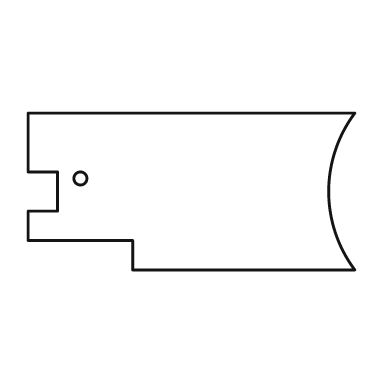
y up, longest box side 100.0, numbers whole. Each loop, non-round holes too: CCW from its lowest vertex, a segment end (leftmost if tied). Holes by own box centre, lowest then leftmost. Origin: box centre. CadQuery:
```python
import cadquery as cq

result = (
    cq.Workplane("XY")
    .moveTo(-18.0, -24.0)
    .lineTo(50.0, -24.0)
    .threePointArc((42.0, 0.0), (50.0, 24.0))
    .lineTo(-50.0, 24.0)
    .lineTo(-50.0, 6.0)
    .lineTo(-41.0, 6.0)
    .lineTo(-41.0, -6.0)
    .lineTo(-50.0, -6.0)
    .lineTo(-50.0, -15.0)
    .lineTo(-18.0, -15.0)
    .close()
    .moveTo(-34.0, 4.0)
    .circle(2.0)
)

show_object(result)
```